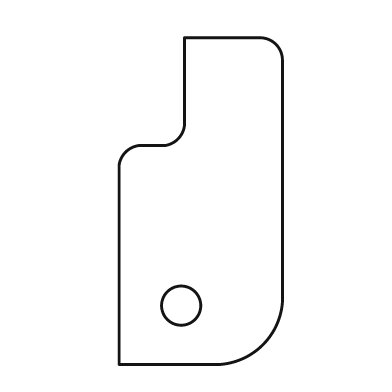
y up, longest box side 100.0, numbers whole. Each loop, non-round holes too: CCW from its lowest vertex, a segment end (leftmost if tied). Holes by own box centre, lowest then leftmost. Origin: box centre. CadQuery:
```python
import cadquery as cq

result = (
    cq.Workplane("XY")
    .moveTo(-25.0, -50.0)
    .lineTo(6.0, -50.0)
    .threePointArc((19.0, -44.0), (25.0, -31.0))
    .lineTo(25.0, 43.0)
    .threePointArc((23.0, 48.0), (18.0, 50.0))
    .lineTo(-5.0, 50.0)
    .lineTo(-5.0, 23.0)
    .threePointArc((-7.0, 19.0), (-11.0, 17.0))
    .lineTo(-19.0, 17.0)
    .threePointArc((-23.0, 15.0), (-25.0, 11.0))
    .close()
    .moveTo(-6.0, -32.0)
    .circle(6.0)
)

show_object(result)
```